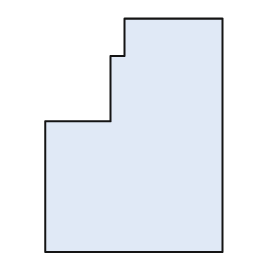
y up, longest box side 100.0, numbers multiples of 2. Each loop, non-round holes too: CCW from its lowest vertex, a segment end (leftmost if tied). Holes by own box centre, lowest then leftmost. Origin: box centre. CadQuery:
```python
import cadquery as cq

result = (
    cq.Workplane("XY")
    .moveTo(-38.0, -50.0)
    .lineTo(38.0, -50.0)
    .lineTo(38.0, 50.0)
    .lineTo(-4.0, 50.0)
    .lineTo(-4.0, 34.0)
    .lineTo(-10.0, 34.0)
    .lineTo(-10.0, 6.0)
    .lineTo(-38.0, 6.0)
    .close()
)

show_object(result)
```